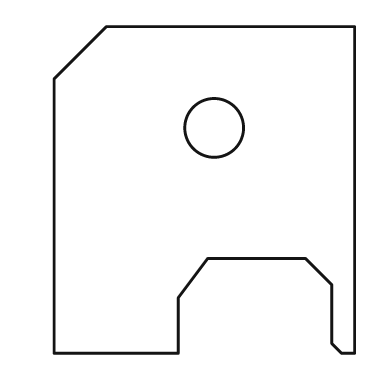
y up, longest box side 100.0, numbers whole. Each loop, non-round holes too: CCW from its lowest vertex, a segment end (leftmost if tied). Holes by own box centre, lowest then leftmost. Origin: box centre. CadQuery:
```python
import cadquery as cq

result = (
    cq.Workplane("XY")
    .moveTo(-46.0, -50.0)
    .lineTo(-8.0, -50.0)
    .lineTo(-8.0, -33.0)
    .lineTo(1.0, -21.0)
    .lineTo(31.0, -21.0)
    .lineTo(39.0, -29.0)
    .lineTo(39.0, -47.0)
    .lineTo(42.0, -50.0)
    .lineTo(46.0, -50.0)
    .lineTo(46.0, 50.0)
    .lineTo(-30.0, 50.0)
    .lineTo(-46.0, 34.0)
    .close()
    .moveTo(3.0, 19.0)
    .circle(9.0)
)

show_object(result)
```